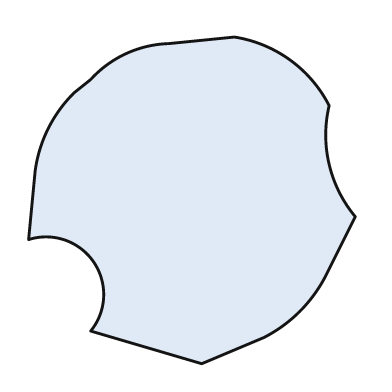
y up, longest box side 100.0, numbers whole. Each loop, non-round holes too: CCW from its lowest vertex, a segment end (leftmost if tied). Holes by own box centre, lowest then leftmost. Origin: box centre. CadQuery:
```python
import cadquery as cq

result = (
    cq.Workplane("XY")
    .moveTo(3.0, -50.0)
    .lineTo(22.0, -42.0)
    .threePointArc((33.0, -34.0), (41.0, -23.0))
    .lineTo(50.0, -5.0)
    .threePointArc((42.0, 11.0), (42.0, 29.0))
    .threePointArc((30.0, 43.0), (13.0, 50.0))
    .lineTo(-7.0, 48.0)
    .threePointArc((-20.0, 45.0), (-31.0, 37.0))
    .lineTo(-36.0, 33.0)
    .threePointArc((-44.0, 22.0), (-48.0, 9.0))
    .lineTo(-50.0, -12.0)
    .threePointArc((-30.0, -19.0), (-31.0, -40.0))
    .close()
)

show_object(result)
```